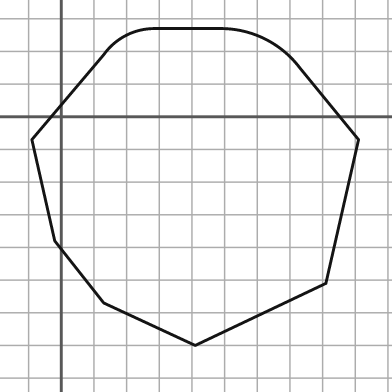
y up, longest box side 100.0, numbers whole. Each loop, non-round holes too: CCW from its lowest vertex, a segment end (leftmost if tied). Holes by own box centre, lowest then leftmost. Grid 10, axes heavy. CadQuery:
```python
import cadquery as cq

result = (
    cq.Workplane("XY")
    .moveTo(41.0, -70.0)
    .lineTo(81.0, -51.0)
    .lineTo(91.0, -7.0)
    .lineTo(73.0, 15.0)
    .threePointArc((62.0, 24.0), (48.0, 27.0))
    .lineTo(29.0, 27.0)
    .threePointArc((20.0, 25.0), (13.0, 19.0))
    .lineTo(-9.0, -7.0)
    .lineTo(-2.0, -38.0)
    .lineTo(13.0, -57.0)
    .close()
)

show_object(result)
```